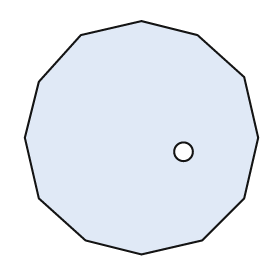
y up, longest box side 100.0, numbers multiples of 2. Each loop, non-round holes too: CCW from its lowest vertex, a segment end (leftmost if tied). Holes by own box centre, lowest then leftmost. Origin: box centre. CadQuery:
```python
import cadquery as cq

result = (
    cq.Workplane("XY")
    .moveTo(0.0, -50.0)
    .lineTo(26.0, -44.0)
    .lineTo(44.0, -26.0)
    .lineTo(50.0, 0.0)
    .lineTo(44.0, 26.0)
    .lineTo(24.0, 44.0)
    .lineTo(0.0, 50.0)
    .lineTo(-26.0, 44.0)
    .lineTo(-44.0, 24.0)
    .lineTo(-50.0, 0.0)
    .lineTo(-44.0, -26.0)
    .lineTo(-24.0, -44.0)
    .close()
    .moveTo(18.0, -6.0)
    .circle(4.0)
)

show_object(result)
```